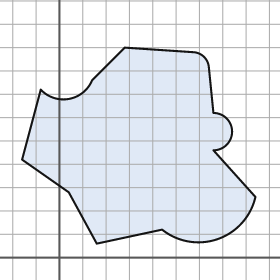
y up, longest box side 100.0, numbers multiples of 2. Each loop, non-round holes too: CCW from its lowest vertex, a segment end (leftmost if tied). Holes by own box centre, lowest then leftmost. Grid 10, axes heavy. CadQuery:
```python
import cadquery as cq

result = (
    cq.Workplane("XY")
    .moveTo(16.0, 6.0)
    .lineTo(44.0, 12.0)
    .threePointArc((68.0, 8.0), (84.0, 26.0))
    .lineTo(66.0, 46.0)
    .threePointArc((74.0, 54.0), (66.0, 62.0))
    .lineTo(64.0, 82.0)
    .threePointArc((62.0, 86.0), (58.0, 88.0))
    .lineTo(28.0, 90.0)
    .lineTo(14.0, 76.0)
    .threePointArc((4.0, 68.0), (-8.0, 72.0))
    .lineTo(-16.0, 42.0)
    .lineTo(4.0, 28.0)
    .close()
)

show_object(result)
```